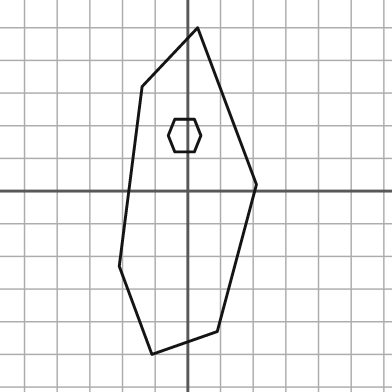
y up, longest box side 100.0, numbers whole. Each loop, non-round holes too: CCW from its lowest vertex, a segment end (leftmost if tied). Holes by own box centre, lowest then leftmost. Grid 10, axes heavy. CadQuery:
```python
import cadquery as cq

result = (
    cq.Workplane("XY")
    .moveTo(-11.0, -50.0)
    .lineTo(9.0, -43.0)
    .lineTo(21.0, 2.0)
    .lineTo(3.0, 50.0)
    .lineTo(-14.0, 32.0)
    .lineTo(-21.0, -23.0)
    .close()
    .moveTo(-4.0, 12.0)
    .lineTo(2.0, 12.0)
    .lineTo(4.0, 17.0)
    .lineTo(2.0, 22.0)
    .lineTo(-4.0, 22.0)
    .lineTo(-6.0, 17.0)
    .close()
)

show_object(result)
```